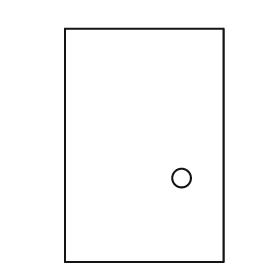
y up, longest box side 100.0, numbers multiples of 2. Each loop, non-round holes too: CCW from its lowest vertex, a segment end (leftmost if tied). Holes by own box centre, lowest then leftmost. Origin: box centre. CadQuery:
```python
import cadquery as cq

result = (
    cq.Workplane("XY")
    .moveTo(-34.0, -50.0)
    .lineTo(34.0, -50.0)
    .lineTo(34.0, 50.0)
    .lineTo(-34.0, 50.0)
    .close()
    .moveTo(16.0, -14.0)
    .circle(4.0)
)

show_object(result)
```